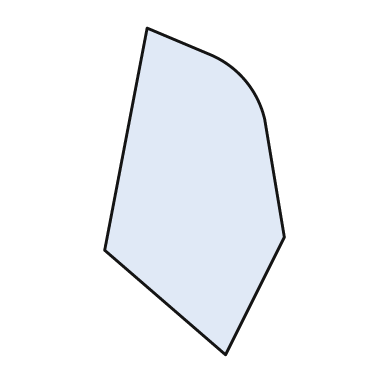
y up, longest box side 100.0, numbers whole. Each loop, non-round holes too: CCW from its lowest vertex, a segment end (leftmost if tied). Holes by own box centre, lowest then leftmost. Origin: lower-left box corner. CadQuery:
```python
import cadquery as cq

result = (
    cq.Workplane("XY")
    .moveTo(37.0, 0.0)
    .lineTo(55.0, 36.0)
    .lineTo(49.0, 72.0)
    .threePointArc((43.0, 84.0), (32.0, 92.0))
    .lineTo(13.0, 100.0)
    .lineTo(0.0, 32.0)
    .close()
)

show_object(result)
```